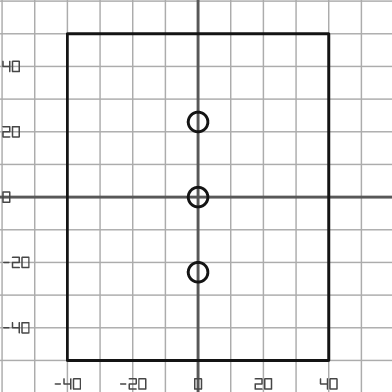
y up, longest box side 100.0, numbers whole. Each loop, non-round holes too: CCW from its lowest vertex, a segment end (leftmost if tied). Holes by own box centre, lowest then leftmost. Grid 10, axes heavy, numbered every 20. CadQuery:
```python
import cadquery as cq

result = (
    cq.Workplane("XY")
    .moveTo(-40.0, -50.0)
    .lineTo(40.0, -50.0)
    .lineTo(40.0, 50.0)
    .lineTo(-40.0, 50.0)
    .close()
    .moveTo(0.0, -23.0)
    .circle(3.0)
    .moveTo(0.0, 0.0)
    .circle(3.0)
    .moveTo(0.0, 23.0)
    .circle(3.0)
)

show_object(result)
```